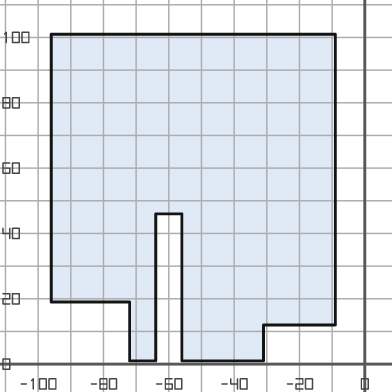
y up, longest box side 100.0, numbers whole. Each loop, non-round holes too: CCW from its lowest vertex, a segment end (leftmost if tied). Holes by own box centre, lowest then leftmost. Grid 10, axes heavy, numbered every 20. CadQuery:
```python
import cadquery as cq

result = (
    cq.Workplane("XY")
    .moveTo(-72.0, 1.0)
    .lineTo(-64.0, 1.0)
    .lineTo(-64.0, 46.0)
    .lineTo(-56.0, 46.0)
    .lineTo(-56.0, 1.0)
    .lineTo(-31.0, 1.0)
    .lineTo(-31.0, 12.0)
    .lineTo(-9.0, 12.0)
    .lineTo(-9.0, 101.0)
    .lineTo(-96.0, 101.0)
    .lineTo(-96.0, 19.0)
    .lineTo(-72.0, 19.0)
    .close()
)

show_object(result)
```